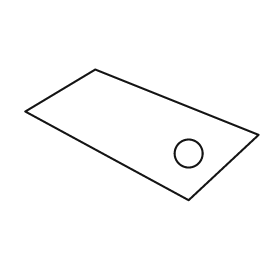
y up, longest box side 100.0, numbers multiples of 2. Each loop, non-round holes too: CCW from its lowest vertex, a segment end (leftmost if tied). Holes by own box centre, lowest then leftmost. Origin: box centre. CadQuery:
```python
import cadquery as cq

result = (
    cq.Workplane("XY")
    .moveTo(20.0, -28.0)
    .lineTo(50.0, 0.0)
    .lineTo(-20.0, 28.0)
    .lineTo(-50.0, 10.0)
    .close()
    .moveTo(20.0, -8.0)
    .circle(6.0)
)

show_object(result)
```